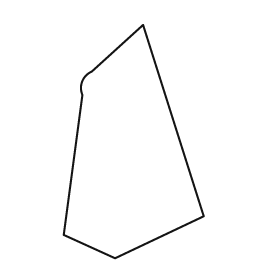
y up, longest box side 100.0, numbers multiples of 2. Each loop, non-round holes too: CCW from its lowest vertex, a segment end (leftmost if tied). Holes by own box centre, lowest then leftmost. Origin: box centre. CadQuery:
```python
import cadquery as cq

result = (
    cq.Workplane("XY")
    .moveTo(-8.0, -50.0)
    .lineTo(30.0, -32.0)
    .lineTo(4.0, 50.0)
    .lineTo(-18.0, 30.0)
    .threePointArc((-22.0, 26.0), (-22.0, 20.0))
    .lineTo(-30.0, -40.0)
    .close()
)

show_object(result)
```